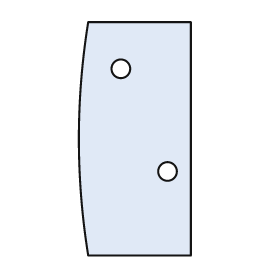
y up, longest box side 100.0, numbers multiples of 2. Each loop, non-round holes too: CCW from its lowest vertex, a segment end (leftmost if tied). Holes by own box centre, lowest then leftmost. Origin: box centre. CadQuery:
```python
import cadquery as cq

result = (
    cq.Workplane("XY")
    .moveTo(-20.0, -50.0)
    .lineTo(24.0, -50.0)
    .lineTo(24.0, 50.0)
    .lineTo(-20.0, 50.0)
    .threePointArc((-24.0, 0.0), (-20.0, -50.0))
    .close()
    .moveTo(14.0, -14.0)
    .circle(4.0)
    .moveTo(-6.0, 30.0)
    .circle(4.0)
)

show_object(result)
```